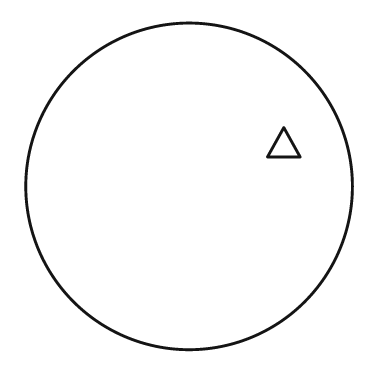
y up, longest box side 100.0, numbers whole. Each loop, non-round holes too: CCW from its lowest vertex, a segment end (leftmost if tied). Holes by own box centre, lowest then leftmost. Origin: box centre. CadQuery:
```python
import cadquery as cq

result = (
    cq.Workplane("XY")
    .moveTo(0.0, 0.0)
    .circle(50.0)
    .moveTo(24.0, 9.0)
    .lineTo(34.0, 9.0)
    .lineTo(29.0, 18.0)
    .close()
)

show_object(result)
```